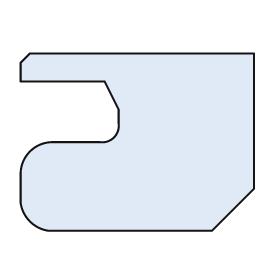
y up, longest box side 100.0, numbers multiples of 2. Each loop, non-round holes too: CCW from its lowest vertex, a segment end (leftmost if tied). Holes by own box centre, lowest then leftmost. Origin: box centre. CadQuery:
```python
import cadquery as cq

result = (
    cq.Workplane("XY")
    .moveTo(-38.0, -38.0)
    .lineTo(32.0, -38.0)
    .lineTo(50.0, -20.0)
    .lineTo(50.0, 38.0)
    .lineTo(-46.0, 38.0)
    .lineTo(-50.0, 34.0)
    .lineTo(-50.0, 26.0)
    .lineTo(-14.0, 26.0)
    .lineTo(-8.0, 14.0)
    .lineTo(-8.0, 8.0)
    .threePointArc((-10.0, 2.0), (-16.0, 0.0))
    .lineTo(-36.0, 0.0)
    .threePointArc((-46.0, -4.0), (-50.0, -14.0))
    .lineTo(-50.0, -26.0)
    .threePointArc((-46.0, -34.0), (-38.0, -38.0))
    .close()
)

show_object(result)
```